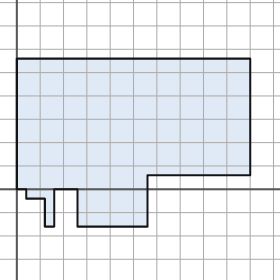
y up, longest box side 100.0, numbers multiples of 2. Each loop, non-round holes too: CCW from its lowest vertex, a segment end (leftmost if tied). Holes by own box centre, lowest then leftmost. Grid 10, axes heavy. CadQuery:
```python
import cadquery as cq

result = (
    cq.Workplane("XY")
    .moveTo(12.0, -16.0)
    .lineTo(16.0, -16.0)
    .lineTo(16.0, 0.0)
    .lineTo(26.0, 0.0)
    .lineTo(26.0, -16.0)
    .lineTo(56.0, -16.0)
    .lineTo(56.0, 6.0)
    .lineTo(100.0, 6.0)
    .lineTo(100.0, 56.0)
    .lineTo(0.0, 56.0)
    .lineTo(0.0, 0.0)
    .lineTo(4.0, 0.0)
    .lineTo(4.0, -4.0)
    .lineTo(12.0, -4.0)
    .close()
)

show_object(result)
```